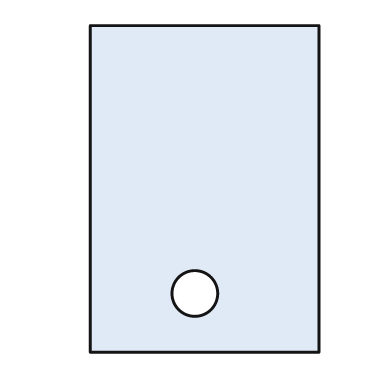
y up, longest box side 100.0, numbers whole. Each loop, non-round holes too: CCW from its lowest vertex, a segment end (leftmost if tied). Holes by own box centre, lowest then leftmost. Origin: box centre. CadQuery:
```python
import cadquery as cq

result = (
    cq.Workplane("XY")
    .moveTo(-35.0, -50.0)
    .lineTo(35.0, -50.0)
    .lineTo(35.0, 50.0)
    .lineTo(-35.0, 50.0)
    .close()
    .moveTo(-3.0, -32.0)
    .circle(7.0)
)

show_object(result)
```